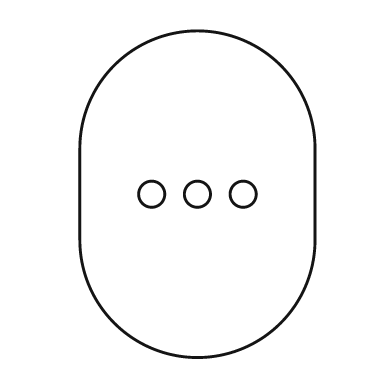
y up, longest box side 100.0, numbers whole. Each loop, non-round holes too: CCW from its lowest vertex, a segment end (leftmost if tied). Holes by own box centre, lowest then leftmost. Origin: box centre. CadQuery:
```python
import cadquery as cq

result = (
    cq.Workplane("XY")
    .moveTo(-36.0, -14.0)
    .threePointArc((0.0, -50.0), (36.0, -14.0))
    .lineTo(36.0, 14.0)
    .threePointArc((0.0, 50.0), (-36.0, 14.0))
    .close()
    .moveTo(-14.0, 0.0)
    .circle(4.0)
    .moveTo(0.0, 0.0)
    .circle(4.0)
    .moveTo(14.0, 0.0)
    .circle(4.0)
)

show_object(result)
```